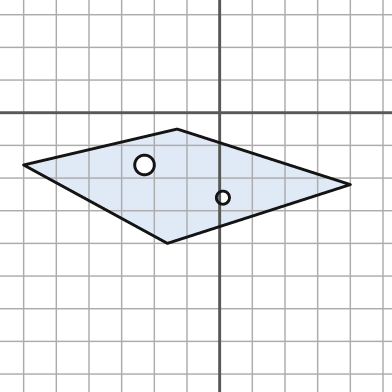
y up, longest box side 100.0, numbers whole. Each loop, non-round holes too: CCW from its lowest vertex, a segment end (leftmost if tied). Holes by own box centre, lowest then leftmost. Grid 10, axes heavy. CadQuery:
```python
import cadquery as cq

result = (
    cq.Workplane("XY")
    .moveTo(-16.0, -40.0)
    .lineTo(40.0, -22.0)
    .lineTo(-13.0, -5.0)
    .lineTo(-60.0, -16.0)
    .close()
    .moveTo(1.0, -26.0)
    .circle(2.0)
    .moveTo(-23.0, -16.0)
    .circle(3.0)
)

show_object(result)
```